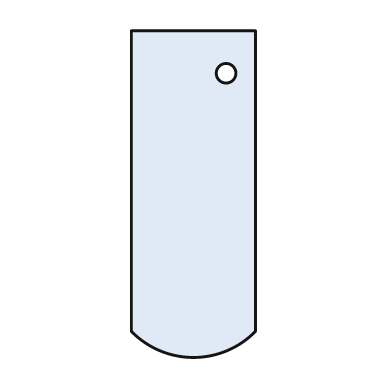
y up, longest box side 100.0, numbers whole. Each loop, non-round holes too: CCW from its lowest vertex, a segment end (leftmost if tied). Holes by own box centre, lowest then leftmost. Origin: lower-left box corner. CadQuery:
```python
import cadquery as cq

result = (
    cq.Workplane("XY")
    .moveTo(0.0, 8.0)
    .threePointArc((19.0, 0.0), (38.0, 8.0))
    .lineTo(38.0, 100.0)
    .lineTo(0.0, 100.0)
    .close()
    .moveTo(29.0, 87.0)
    .circle(3.0)
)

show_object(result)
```